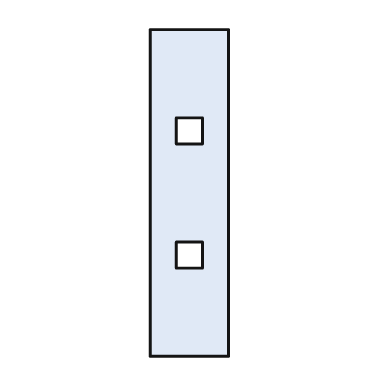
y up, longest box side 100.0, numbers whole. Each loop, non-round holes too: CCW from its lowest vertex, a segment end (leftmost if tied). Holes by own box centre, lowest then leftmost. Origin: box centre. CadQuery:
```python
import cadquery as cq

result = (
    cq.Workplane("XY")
    .moveTo(-12.0, -50.0)
    .lineTo(12.0, -50.0)
    .lineTo(12.0, 50.0)
    .lineTo(-12.0, 50.0)
    .close()
    .moveTo(-4.0, -23.0)
    .lineTo(4.0, -23.0)
    .lineTo(4.0, -15.0)
    .lineTo(-4.0, -15.0)
    .close()
    .moveTo(-4.0, 15.0)
    .lineTo(4.0, 15.0)
    .lineTo(4.0, 23.0)
    .lineTo(-4.0, 23.0)
    .close()
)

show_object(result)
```